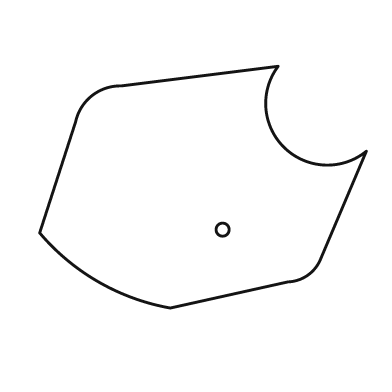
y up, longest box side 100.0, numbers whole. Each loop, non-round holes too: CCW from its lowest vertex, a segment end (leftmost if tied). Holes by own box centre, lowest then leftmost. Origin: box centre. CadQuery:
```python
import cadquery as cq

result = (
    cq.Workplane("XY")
    .moveTo(-10.0, -37.0)
    .lineTo(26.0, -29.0)
    .threePointArc((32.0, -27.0), (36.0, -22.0))
    .lineTo(50.0, 11.0)
    .threePointArc((25.0, 12.0), (23.0, 37.0))
    .lineTo(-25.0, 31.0)
    .threePointArc((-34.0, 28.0), (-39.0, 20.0))
    .lineTo(-50.0, -14.0)
    .threePointArc((-32.0, -29.0), (-10.0, -37.0))
    .close()
    .moveTo(6.0, -13.0)
    .circle(2.0)
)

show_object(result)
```